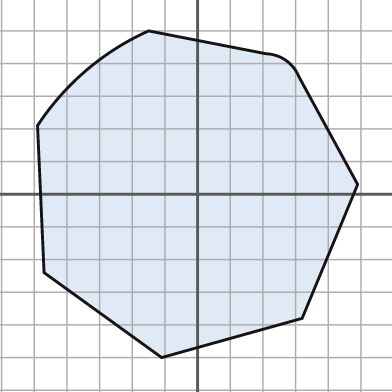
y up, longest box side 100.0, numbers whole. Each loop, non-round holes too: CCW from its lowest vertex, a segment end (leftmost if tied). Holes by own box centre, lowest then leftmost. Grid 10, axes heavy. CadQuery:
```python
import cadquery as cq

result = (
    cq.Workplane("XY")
    .moveTo(-11.0, -50.0)
    .lineTo(32.0, -38.0)
    .lineTo(49.0, 3.0)
    .lineTo(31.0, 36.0)
    .threePointArc((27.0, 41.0), (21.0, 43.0))
    .lineTo(-15.0, 50.0)
    .threePointArc((-34.0, 38.0), (-49.0, 21.0))
    .lineTo(-47.0, -24.0)
    .close()
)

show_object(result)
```